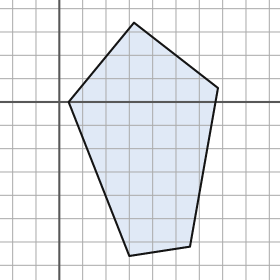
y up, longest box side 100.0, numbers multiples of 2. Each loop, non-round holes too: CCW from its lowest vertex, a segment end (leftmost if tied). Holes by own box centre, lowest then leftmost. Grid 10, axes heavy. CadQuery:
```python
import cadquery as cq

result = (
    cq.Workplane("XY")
    .moveTo(30.0, -66.0)
    .lineTo(56.0, -62.0)
    .lineTo(68.0, 6.0)
    .lineTo(32.0, 34.0)
    .lineTo(4.0, 0.0)
    .close()
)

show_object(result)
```